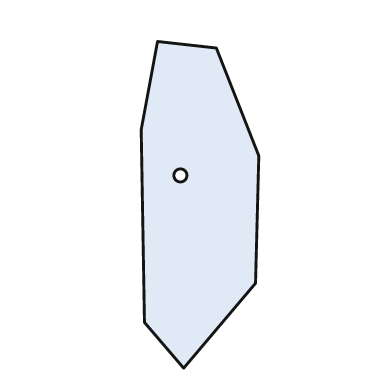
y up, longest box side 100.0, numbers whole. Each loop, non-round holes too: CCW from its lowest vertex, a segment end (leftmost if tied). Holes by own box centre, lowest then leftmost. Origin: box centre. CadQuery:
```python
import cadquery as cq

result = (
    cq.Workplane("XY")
    .moveTo(-5.0, -50.0)
    .lineTo(17.0, -24.0)
    .lineTo(18.0, 15.0)
    .lineTo(5.0, 48.0)
    .lineTo(-13.0, 50.0)
    .lineTo(-18.0, 23.0)
    .lineTo(-17.0, -36.0)
    .close()
    .moveTo(-6.0, 9.0)
    .circle(2.0)
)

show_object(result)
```